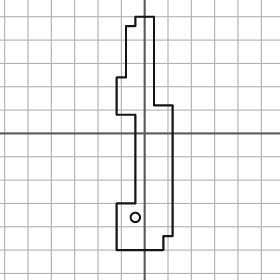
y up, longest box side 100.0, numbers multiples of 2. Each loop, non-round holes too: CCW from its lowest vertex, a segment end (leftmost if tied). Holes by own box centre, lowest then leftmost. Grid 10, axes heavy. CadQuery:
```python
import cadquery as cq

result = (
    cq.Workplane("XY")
    .moveTo(-12.0, -50.0)
    .lineTo(8.0, -50.0)
    .lineTo(8.0, -44.0)
    .lineTo(12.0, -44.0)
    .lineTo(12.0, 12.0)
    .lineTo(4.0, 12.0)
    .lineTo(4.0, 50.0)
    .lineTo(-4.0, 50.0)
    .lineTo(-4.0, 46.0)
    .lineTo(-8.0, 46.0)
    .lineTo(-8.0, 24.0)
    .lineTo(-12.0, 24.0)
    .lineTo(-12.0, 8.0)
    .lineTo(-4.0, 8.0)
    .lineTo(-4.0, -30.0)
    .lineTo(-12.0, -30.0)
    .close()
    .moveTo(-4.0, -36.0)
    .circle(2.0)
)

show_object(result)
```